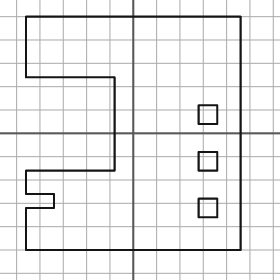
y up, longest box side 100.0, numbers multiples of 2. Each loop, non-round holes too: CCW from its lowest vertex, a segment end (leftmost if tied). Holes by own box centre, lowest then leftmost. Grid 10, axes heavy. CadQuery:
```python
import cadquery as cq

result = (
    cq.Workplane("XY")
    .moveTo(-46.0, -50.0)
    .lineTo(46.0, -50.0)
    .lineTo(46.0, 50.0)
    .lineTo(-46.0, 50.0)
    .lineTo(-46.0, 24.0)
    .lineTo(-8.0, 24.0)
    .lineTo(-8.0, -16.0)
    .lineTo(-46.0, -16.0)
    .lineTo(-46.0, -26.0)
    .lineTo(-34.0, -26.0)
    .lineTo(-34.0, -32.0)
    .lineTo(-46.0, -32.0)
    .close()
    .moveTo(28.0, -36.0)
    .lineTo(36.0, -36.0)
    .lineTo(36.0, -28.0)
    .lineTo(28.0, -28.0)
    .close()
    .moveTo(28.0, -16.0)
    .lineTo(36.0, -16.0)
    .lineTo(36.0, -8.0)
    .lineTo(28.0, -8.0)
    .close()
    .moveTo(28.0, 4.0)
    .lineTo(36.0, 4.0)
    .lineTo(36.0, 12.0)
    .lineTo(28.0, 12.0)
    .close()
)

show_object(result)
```